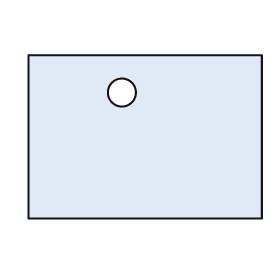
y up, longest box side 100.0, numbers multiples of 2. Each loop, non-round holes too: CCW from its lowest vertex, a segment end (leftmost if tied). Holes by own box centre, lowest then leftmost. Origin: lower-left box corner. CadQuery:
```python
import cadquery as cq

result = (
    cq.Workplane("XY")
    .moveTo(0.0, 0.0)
    .lineTo(100.0, 0.0)
    .lineTo(100.0, 70.0)
    .lineTo(0.0, 70.0)
    .close()
    .moveTo(40.0, 54.0)
    .circle(6.0)
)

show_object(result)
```